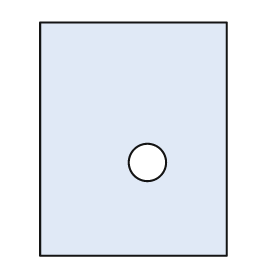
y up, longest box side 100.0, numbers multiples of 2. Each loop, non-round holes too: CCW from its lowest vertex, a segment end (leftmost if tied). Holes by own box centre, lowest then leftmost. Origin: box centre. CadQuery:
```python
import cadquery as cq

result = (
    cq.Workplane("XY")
    .moveTo(-40.0, -50.0)
    .lineTo(40.0, -50.0)
    .lineTo(40.0, 50.0)
    .lineTo(-40.0, 50.0)
    .close()
    .moveTo(6.0, -10.0)
    .circle(8.0)
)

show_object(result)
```